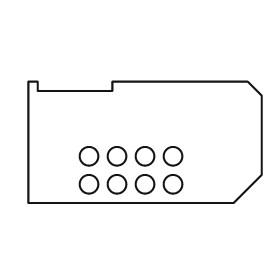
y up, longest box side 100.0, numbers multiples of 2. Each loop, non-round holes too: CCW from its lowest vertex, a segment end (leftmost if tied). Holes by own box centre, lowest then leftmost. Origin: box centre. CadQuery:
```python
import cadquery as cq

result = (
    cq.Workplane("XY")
    .moveTo(-50.0, -26.0)
    .lineTo(38.0, -26.0)
    .lineTo(50.0, -14.0)
    .lineTo(50.0, 20.0)
    .lineTo(44.0, 26.0)
    .lineTo(-14.0, 26.0)
    .lineTo(-14.0, 22.0)
    .lineTo(-46.0, 22.0)
    .lineTo(-46.0, 26.0)
    .lineTo(-50.0, 26.0)
    .close()
    .moveTo(-24.0, -18.0)
    .circle(4.0)
    .moveTo(-12.0, -18.0)
    .circle(4.0)
    .moveTo(0.0, -18.0)
    .circle(4.0)
    .moveTo(12.0, -18.0)
    .circle(4.0)
    .moveTo(-24.0, -6.0)
    .circle(4.0)
    .moveTo(-12.0, -6.0)
    .circle(4.0)
    .moveTo(0.0, -6.0)
    .circle(4.0)
    .moveTo(12.0, -6.0)
    .circle(4.0)
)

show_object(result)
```